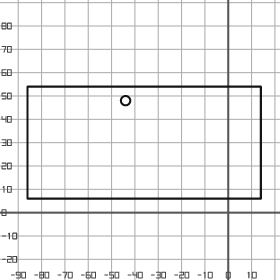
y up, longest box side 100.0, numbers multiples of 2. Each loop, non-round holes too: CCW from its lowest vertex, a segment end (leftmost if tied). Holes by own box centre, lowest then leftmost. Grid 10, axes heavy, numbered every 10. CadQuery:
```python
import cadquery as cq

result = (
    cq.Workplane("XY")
    .moveTo(-86.0, 6.0)
    .lineTo(14.0, 6.0)
    .lineTo(14.0, 54.0)
    .lineTo(-86.0, 54.0)
    .close()
    .moveTo(-44.0, 48.0)
    .circle(2.0)
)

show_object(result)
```